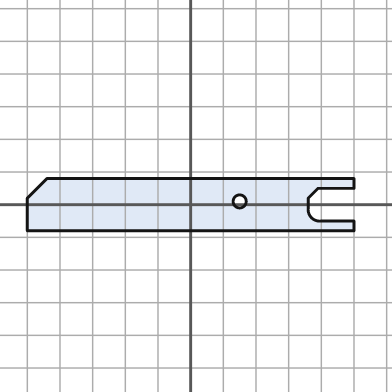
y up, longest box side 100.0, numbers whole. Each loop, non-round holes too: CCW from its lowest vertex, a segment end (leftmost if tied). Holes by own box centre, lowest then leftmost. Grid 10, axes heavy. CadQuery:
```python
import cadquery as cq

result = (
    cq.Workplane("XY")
    .moveTo(-50.0, -8.0)
    .lineTo(50.0, -8.0)
    .lineTo(50.0, -5.0)
    .lineTo(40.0, -5.0)
    .threePointArc((37.0, -4.0), (36.0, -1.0))
    .lineTo(36.0, 2.0)
    .lineTo(39.0, 5.0)
    .lineTo(50.0, 5.0)
    .lineTo(50.0, 8.0)
    .lineTo(-44.0, 8.0)
    .lineTo(-50.0, 2.0)
    .close()
    .moveTo(15.0, 1.0)
    .circle(2.0)
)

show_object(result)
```